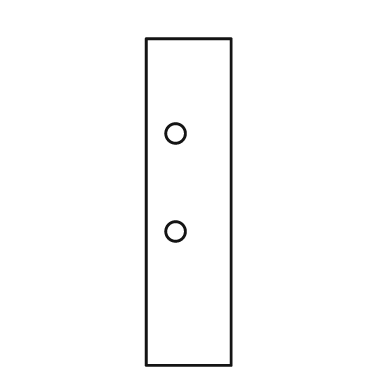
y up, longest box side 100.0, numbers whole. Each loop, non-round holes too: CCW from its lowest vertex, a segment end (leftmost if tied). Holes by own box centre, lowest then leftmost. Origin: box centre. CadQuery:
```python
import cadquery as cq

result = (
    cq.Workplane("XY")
    .moveTo(-13.0, -50.0)
    .lineTo(13.0, -50.0)
    .lineTo(13.0, 50.0)
    .lineTo(-13.0, 50.0)
    .close()
    .moveTo(-4.0, -9.0)
    .circle(3.0)
    .moveTo(-4.0, 21.0)
    .circle(3.0)
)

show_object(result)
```